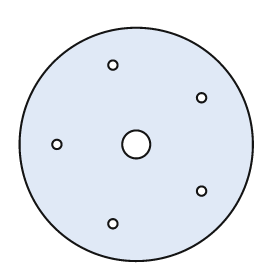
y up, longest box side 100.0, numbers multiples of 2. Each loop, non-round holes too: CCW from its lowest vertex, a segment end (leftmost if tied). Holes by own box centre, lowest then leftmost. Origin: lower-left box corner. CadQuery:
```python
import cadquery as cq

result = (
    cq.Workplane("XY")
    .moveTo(50.0, 50.0)
    .circle(50.0)
    .moveTo(40.0, 16.0)
    .circle(2.0)
    .moveTo(78.0, 30.0)
    .circle(2.0)
    .moveTo(16.0, 50.0)
    .circle(2.0)
    .moveTo(50.0, 50.0)
    .circle(6.0)
    .moveTo(78.0, 70.0)
    .circle(2.0)
    .moveTo(40.0, 84.0)
    .circle(2.0)
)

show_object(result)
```